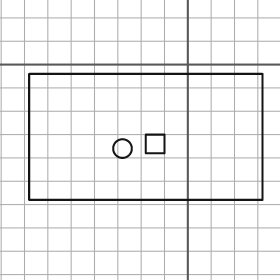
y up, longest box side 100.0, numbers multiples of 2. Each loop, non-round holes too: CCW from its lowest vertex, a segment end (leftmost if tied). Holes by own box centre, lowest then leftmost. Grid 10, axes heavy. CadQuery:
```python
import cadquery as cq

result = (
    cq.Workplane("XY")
    .moveTo(-68.0, -58.0)
    .lineTo(32.0, -58.0)
    .lineTo(32.0, -4.0)
    .lineTo(-68.0, -4.0)
    .close()
    .moveTo(-28.0, -36.0)
    .circle(4.0)
    .moveTo(-18.0, -38.0)
    .lineTo(-10.0, -38.0)
    .lineTo(-10.0, -30.0)
    .lineTo(-18.0, -30.0)
    .close()
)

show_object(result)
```